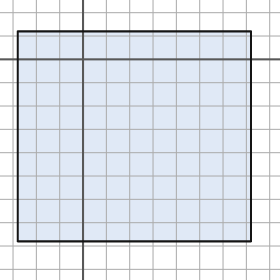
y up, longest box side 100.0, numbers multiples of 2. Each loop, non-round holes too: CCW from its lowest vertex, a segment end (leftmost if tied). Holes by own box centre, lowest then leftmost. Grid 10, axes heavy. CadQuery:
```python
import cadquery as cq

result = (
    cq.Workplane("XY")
    .moveTo(-28.0, -78.0)
    .lineTo(72.0, -78.0)
    .lineTo(72.0, 12.0)
    .lineTo(-28.0, 12.0)
    .close()
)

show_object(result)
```